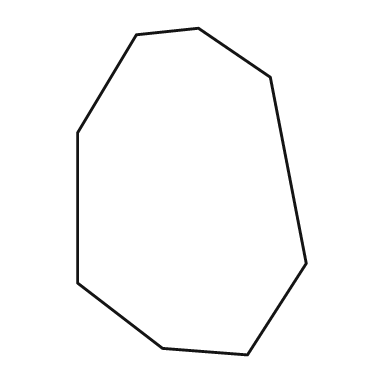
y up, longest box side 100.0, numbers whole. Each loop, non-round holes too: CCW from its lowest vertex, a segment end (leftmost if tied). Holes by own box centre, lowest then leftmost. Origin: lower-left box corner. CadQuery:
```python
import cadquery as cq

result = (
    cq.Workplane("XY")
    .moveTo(52.0, 0.0)
    .lineTo(70.0, 28.0)
    .lineTo(59.0, 85.0)
    .lineTo(37.0, 100.0)
    .lineTo(18.0, 98.0)
    .lineTo(0.0, 68.0)
    .lineTo(0.0, 22.0)
    .lineTo(26.0, 2.0)
    .close()
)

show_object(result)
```